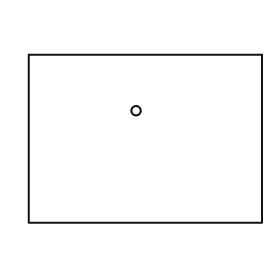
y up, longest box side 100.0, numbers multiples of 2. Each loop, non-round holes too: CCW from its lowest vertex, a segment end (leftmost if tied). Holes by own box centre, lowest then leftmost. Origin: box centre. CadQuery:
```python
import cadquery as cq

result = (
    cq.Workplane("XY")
    .moveTo(-50.0, -36.0)
    .lineTo(50.0, -36.0)
    .lineTo(50.0, 36.0)
    .lineTo(-50.0, 36.0)
    .close()
    .moveTo(-4.0, 12.0)
    .circle(2.0)
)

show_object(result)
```